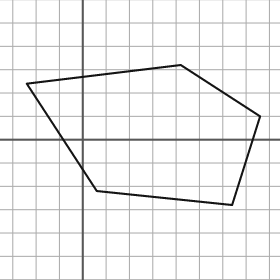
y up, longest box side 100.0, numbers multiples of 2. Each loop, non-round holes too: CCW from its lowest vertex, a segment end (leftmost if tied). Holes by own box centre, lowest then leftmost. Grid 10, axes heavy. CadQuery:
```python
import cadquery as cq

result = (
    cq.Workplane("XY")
    .moveTo(64.0, -28.0)
    .lineTo(76.0, 10.0)
    .lineTo(42.0, 32.0)
    .lineTo(-24.0, 24.0)
    .lineTo(6.0, -22.0)
    .close()
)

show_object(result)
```